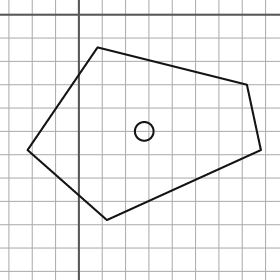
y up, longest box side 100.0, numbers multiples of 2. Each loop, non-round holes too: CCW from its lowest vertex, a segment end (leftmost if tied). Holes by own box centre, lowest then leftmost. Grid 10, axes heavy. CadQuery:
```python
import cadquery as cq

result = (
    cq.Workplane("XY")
    .moveTo(12.0, -88.0)
    .lineTo(78.0, -58.0)
    .lineTo(72.0, -30.0)
    .lineTo(8.0, -14.0)
    .lineTo(-22.0, -58.0)
    .close()
    .moveTo(28.0, -50.0)
    .circle(4.0)
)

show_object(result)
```